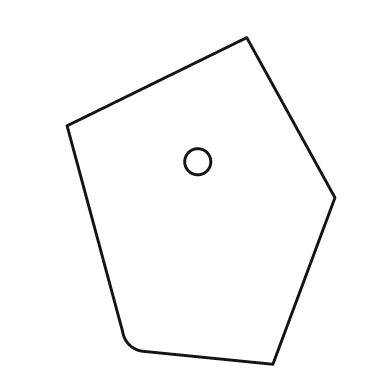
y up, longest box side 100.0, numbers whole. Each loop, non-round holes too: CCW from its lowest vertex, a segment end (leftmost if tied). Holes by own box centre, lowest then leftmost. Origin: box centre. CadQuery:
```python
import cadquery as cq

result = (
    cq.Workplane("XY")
    .moveTo(22.0, -50.0)
    .lineTo(41.0, 1.0)
    .lineTo(14.0, 50.0)
    .lineTo(-41.0, 23.0)
    .lineTo(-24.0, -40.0)
    .threePointArc((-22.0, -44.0), (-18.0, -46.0))
    .close()
    .moveTo(-1.0, 12.0)
    .circle(4.0)
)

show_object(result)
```